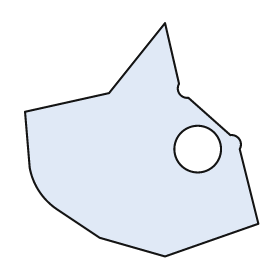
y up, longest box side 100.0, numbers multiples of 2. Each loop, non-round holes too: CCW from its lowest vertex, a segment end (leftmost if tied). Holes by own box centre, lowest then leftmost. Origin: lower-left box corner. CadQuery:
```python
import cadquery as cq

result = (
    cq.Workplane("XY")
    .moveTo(60.0, 0.0)
    .lineTo(100.0, 14.0)
    .lineTo(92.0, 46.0)
    .threePointArc((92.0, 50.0), (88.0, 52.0))
    .lineTo(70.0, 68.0)
    .threePointArc((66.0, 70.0), (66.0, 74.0))
    .lineTo(60.0, 100.0)
    .lineTo(36.0, 70.0)
    .lineTo(0.0, 62.0)
    .lineTo(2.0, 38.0)
    .threePointArc((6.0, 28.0), (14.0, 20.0))
    .lineTo(32.0, 8.0)
    .close()
    .moveTo(74.0, 46.0)
    .circle(10.0)
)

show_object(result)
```